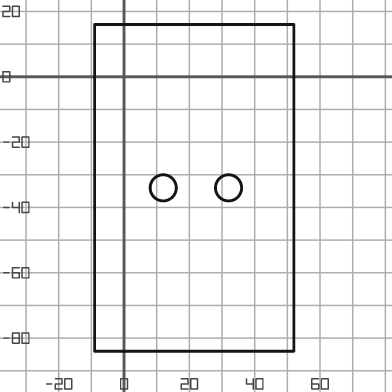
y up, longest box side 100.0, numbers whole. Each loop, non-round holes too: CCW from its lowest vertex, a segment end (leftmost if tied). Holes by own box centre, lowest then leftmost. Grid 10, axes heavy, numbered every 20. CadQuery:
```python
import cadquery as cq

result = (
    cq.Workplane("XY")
    .moveTo(-9.0, -84.0)
    .lineTo(52.0, -84.0)
    .lineTo(52.0, 16.0)
    .lineTo(-9.0, 16.0)
    .close()
    .moveTo(12.0, -34.0)
    .circle(4.0)
    .moveTo(32.0, -34.0)
    .circle(4.0)
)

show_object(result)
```